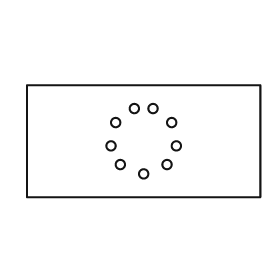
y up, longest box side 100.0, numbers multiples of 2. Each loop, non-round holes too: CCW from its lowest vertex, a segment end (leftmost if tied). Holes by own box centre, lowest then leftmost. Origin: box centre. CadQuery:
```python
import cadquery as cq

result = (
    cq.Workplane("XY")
    .moveTo(-50.0, -24.0)
    .lineTo(50.0, -24.0)
    .lineTo(50.0, 24.0)
    .lineTo(-50.0, 24.0)
    .close()
    .moveTo(0.0, -14.0)
    .circle(2.0)
    .moveTo(-10.0, -10.0)
    .circle(2.0)
    .moveTo(10.0, -10.0)
    .circle(2.0)
    .moveTo(-14.0, -2.0)
    .circle(2.0)
    .moveTo(14.0, -2.0)
    .circle(2.0)
    .moveTo(-12.0, 8.0)
    .circle(2.0)
    .moveTo(12.0, 8.0)
    .circle(2.0)
    .moveTo(-4.0, 14.0)
    .circle(2.0)
    .moveTo(4.0, 14.0)
    .circle(2.0)
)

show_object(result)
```